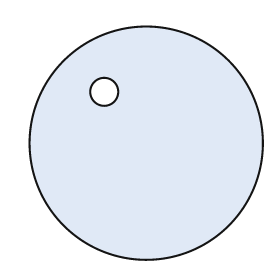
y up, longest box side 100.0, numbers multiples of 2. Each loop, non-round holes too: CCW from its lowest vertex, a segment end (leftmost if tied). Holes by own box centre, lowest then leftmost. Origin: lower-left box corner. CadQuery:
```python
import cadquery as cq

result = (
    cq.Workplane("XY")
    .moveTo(50.0, 50.0)
    .circle(50.0)
    .moveTo(32.0, 72.0)
    .circle(6.0)
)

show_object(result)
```